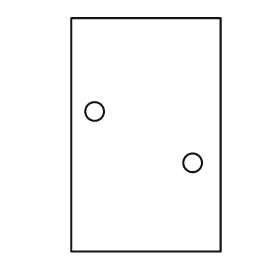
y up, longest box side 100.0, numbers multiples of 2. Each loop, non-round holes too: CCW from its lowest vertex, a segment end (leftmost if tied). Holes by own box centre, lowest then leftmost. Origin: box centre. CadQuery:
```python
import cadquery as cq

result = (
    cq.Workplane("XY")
    .moveTo(-32.0, -50.0)
    .lineTo(32.0, -50.0)
    .lineTo(32.0, 50.0)
    .lineTo(-32.0, 50.0)
    .close()
    .moveTo(20.0, -12.0)
    .circle(4.0)
    .moveTo(-22.0, 10.0)
    .circle(4.0)
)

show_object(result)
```